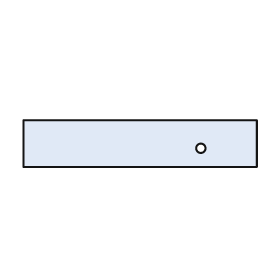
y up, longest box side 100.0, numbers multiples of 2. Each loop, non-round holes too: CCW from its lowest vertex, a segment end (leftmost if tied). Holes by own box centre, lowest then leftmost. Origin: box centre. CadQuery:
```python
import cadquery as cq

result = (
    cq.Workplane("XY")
    .moveTo(-50.0, -10.0)
    .lineTo(50.0, -10.0)
    .lineTo(50.0, 10.0)
    .lineTo(-50.0, 10.0)
    .close()
    .moveTo(26.0, -2.0)
    .circle(2.0)
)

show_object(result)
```